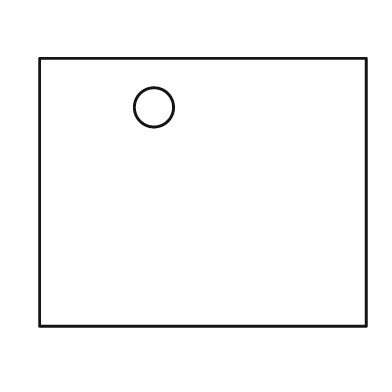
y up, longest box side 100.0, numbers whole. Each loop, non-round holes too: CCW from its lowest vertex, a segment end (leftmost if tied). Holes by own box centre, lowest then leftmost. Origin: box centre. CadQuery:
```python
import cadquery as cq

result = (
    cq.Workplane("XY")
    .moveTo(-50.0, -41.0)
    .lineTo(50.0, -41.0)
    .lineTo(50.0, 41.0)
    .lineTo(-50.0, 41.0)
    .close()
    .moveTo(-15.0, 26.0)
    .circle(6.0)
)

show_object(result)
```